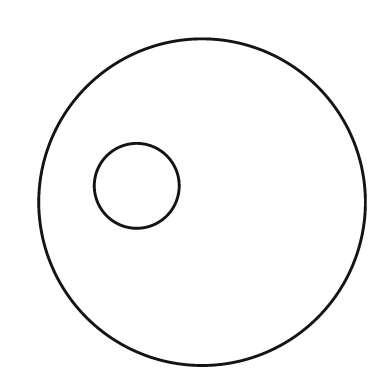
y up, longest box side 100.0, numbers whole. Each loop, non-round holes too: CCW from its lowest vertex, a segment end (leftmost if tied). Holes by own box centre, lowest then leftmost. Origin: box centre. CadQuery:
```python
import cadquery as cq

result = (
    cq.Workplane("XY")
    .moveTo(0.0, 0.0)
    .circle(50.0)
    .moveTo(-20.0, 5.0)
    .circle(13.0)
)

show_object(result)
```